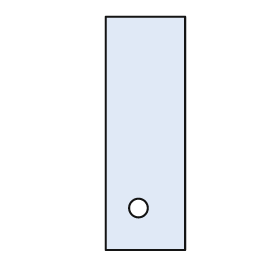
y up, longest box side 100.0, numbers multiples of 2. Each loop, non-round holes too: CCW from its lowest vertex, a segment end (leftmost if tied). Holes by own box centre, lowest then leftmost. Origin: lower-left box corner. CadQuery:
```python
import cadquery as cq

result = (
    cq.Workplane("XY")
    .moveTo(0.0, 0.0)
    .lineTo(34.0, 0.0)
    .lineTo(34.0, 100.0)
    .lineTo(0.0, 100.0)
    .close()
    .moveTo(14.0, 18.0)
    .circle(4.0)
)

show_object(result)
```